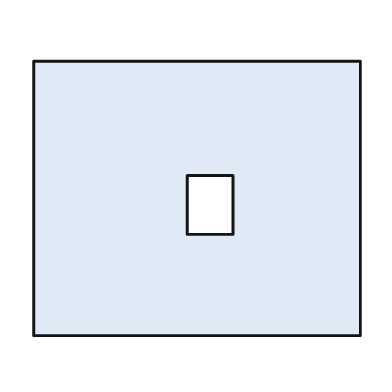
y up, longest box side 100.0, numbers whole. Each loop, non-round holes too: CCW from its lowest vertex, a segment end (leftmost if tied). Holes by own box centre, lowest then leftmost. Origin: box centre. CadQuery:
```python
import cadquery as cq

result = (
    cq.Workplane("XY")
    .moveTo(-50.0, -42.0)
    .lineTo(50.0, -42.0)
    .lineTo(50.0, 42.0)
    .lineTo(-50.0, 42.0)
    .close()
    .moveTo(-3.0, -11.0)
    .lineTo(11.0, -11.0)
    .lineTo(11.0, 7.0)
    .lineTo(-3.0, 7.0)
    .close()
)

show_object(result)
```